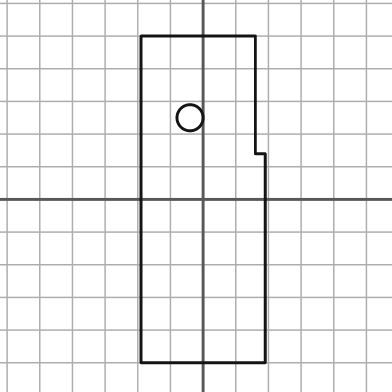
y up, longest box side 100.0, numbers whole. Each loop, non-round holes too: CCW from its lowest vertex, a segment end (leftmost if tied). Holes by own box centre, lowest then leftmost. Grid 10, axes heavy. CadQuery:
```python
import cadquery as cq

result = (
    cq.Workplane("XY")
    .moveTo(-19.0, -50.0)
    .lineTo(19.0, -50.0)
    .lineTo(19.0, 14.0)
    .lineTo(16.0, 14.0)
    .lineTo(16.0, 50.0)
    .lineTo(-19.0, 50.0)
    .close()
    .moveTo(-4.0, 25.0)
    .circle(4.0)
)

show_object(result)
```